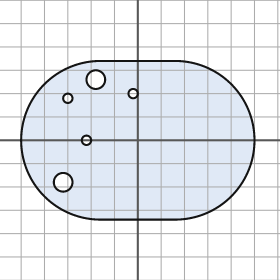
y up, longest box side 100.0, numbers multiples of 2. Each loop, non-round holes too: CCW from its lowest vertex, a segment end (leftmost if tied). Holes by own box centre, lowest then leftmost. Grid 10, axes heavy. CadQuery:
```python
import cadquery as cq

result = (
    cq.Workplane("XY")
    .moveTo(-16.0, -34.0)
    .lineTo(16.0, -34.0)
    .threePointArc((50.0, 0.0), (16.0, 34.0))
    .lineTo(-16.0, 34.0)
    .threePointArc((-50.0, 0.0), (-16.0, -34.0))
    .close()
    .moveTo(-32.0, -18.0)
    .circle(4.0)
    .moveTo(-22.0, 0.0)
    .circle(2.0)
    .moveTo(-30.0, 18.0)
    .circle(2.0)
    .moveTo(-2.0, 20.0)
    .circle(2.0)
    .moveTo(-18.0, 26.0)
    .circle(4.0)
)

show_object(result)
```